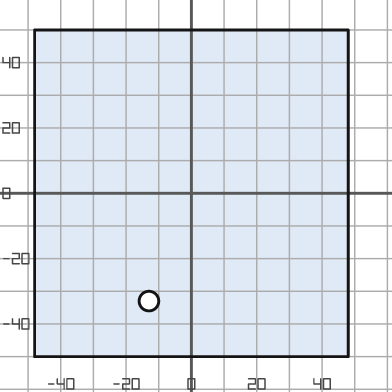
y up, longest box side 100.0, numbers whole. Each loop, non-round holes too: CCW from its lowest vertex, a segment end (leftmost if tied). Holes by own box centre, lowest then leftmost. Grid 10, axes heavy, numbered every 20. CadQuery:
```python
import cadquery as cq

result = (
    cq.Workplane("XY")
    .moveTo(-48.0, -50.0)
    .lineTo(48.0, -50.0)
    .lineTo(48.0, 50.0)
    .lineTo(-48.0, 50.0)
    .close()
    .moveTo(-13.0, -33.0)
    .circle(3.0)
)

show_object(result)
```